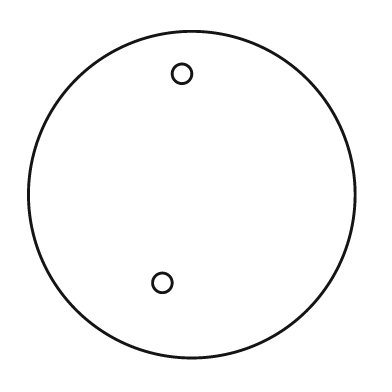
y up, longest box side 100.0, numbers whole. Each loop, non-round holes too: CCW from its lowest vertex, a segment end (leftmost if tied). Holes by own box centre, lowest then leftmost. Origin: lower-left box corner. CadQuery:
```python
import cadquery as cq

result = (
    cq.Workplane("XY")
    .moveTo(50.0, 50.0)
    .circle(50.0)
    .moveTo(41.0, 23.0)
    .circle(3.0)
    .moveTo(47.0, 87.0)
    .circle(3.0)
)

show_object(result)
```